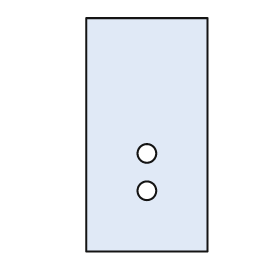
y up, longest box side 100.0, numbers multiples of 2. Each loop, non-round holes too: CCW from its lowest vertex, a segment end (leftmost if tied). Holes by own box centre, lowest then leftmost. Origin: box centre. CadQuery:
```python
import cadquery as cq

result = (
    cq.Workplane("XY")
    .moveTo(-26.0, -50.0)
    .lineTo(26.0, -50.0)
    .lineTo(26.0, 50.0)
    .lineTo(-26.0, 50.0)
    .close()
    .moveTo(0.0, -24.0)
    .circle(4.0)
    .moveTo(0.0, -8.0)
    .circle(4.0)
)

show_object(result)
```